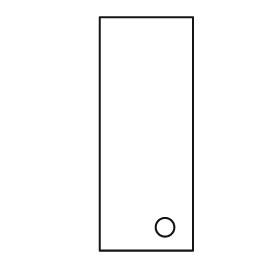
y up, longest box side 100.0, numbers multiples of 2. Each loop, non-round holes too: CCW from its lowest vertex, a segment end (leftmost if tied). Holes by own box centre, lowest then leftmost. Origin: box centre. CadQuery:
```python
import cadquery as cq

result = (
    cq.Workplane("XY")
    .moveTo(-20.0, -50.0)
    .lineTo(20.0, -50.0)
    .lineTo(20.0, 50.0)
    .lineTo(-20.0, 50.0)
    .close()
    .moveTo(8.0, -40.0)
    .circle(4.0)
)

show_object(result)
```